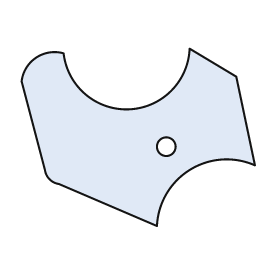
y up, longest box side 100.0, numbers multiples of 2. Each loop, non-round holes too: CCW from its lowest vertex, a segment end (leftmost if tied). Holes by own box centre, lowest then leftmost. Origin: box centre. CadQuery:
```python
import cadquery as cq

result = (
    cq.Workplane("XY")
    .moveTo(8.0, -38.0)
    .threePointArc((22.0, -14.0), (50.0, -12.0))
    .lineTo(42.0, 26.0)
    .lineTo(22.0, 38.0)
    .threePointArc((-4.0, 12.0), (-32.0, 36.0))
    .threePointArc((-44.0, 34.0), (-50.0, 24.0))
    .lineTo(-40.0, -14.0)
    .threePointArc((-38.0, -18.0), (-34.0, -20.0))
    .close()
    .moveTo(12.0, -4.0)
    .circle(4.0)
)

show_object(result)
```